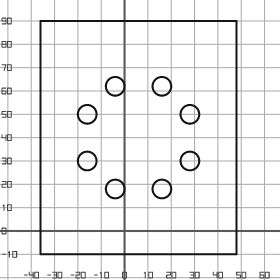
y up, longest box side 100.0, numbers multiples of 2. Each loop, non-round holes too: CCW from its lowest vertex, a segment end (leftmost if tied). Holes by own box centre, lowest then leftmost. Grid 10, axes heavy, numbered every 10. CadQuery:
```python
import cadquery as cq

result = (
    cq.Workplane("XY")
    .moveTo(-36.0, -10.0)
    .lineTo(48.0, -10.0)
    .lineTo(48.0, 90.0)
    .lineTo(-36.0, 90.0)
    .close()
    .moveTo(-4.0, 18.0)
    .circle(4.0)
    .moveTo(16.0, 18.0)
    .circle(4.0)
    .moveTo(-16.0, 30.0)
    .circle(4.0)
    .moveTo(28.0, 30.0)
    .circle(4.0)
    .moveTo(-16.0, 50.0)
    .circle(4.0)
    .moveTo(28.0, 50.0)
    .circle(4.0)
    .moveTo(-4.0, 62.0)
    .circle(4.0)
    .moveTo(16.0, 62.0)
    .circle(4.0)
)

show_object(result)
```